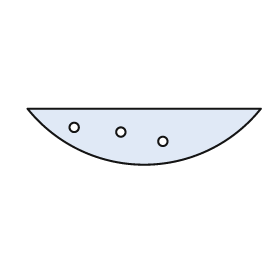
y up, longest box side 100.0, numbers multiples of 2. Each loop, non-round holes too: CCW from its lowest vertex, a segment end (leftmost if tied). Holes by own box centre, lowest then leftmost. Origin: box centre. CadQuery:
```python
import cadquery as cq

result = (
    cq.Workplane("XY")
    .moveTo(-50.0, 12.0)
    .threePointArc((0.0, -12.0), (50.0, 12.0))
    .close()
    .moveTo(8.0, -2.0)
    .circle(2.0)
    .moveTo(-10.0, 2.0)
    .circle(2.0)
    .moveTo(-30.0, 4.0)
    .circle(2.0)
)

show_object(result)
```